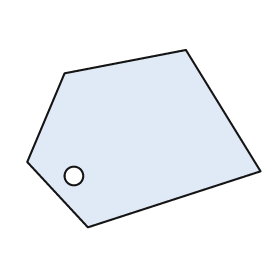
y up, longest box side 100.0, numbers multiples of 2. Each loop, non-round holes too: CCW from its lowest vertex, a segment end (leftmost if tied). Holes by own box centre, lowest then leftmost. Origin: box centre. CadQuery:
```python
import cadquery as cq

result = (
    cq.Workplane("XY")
    .moveTo(-24.0, -38.0)
    .lineTo(50.0, -14.0)
    .lineTo(18.0, 38.0)
    .lineTo(-34.0, 28.0)
    .lineTo(-50.0, -10.0)
    .close()
    .moveTo(-30.0, -16.0)
    .circle(4.0)
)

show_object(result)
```